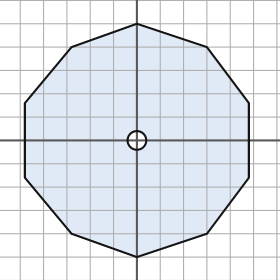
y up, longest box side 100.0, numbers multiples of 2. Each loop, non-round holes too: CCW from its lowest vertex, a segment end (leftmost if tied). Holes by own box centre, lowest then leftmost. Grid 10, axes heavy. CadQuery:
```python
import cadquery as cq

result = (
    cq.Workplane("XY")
    .moveTo(0.0, -50.0)
    .lineTo(30.0, -40.0)
    .lineTo(48.0, -16.0)
    .lineTo(48.0, 16.0)
    .lineTo(30.0, 40.0)
    .lineTo(0.0, 50.0)
    .lineTo(-28.0, 40.0)
    .lineTo(-48.0, 16.0)
    .lineTo(-48.0, -16.0)
    .lineTo(-28.0, -40.0)
    .close()
    .moveTo(0.0, 0.0)
    .circle(4.0)
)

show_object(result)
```